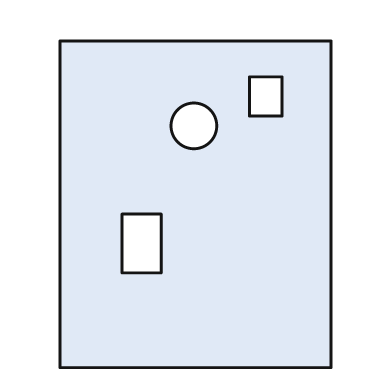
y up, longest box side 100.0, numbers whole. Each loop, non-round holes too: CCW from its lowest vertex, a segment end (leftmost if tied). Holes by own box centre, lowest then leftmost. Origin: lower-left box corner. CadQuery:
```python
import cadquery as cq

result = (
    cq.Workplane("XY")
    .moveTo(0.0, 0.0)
    .lineTo(83.0, 0.0)
    .lineTo(83.0, 100.0)
    .lineTo(0.0, 100.0)
    .close()
    .moveTo(19.0, 29.0)
    .lineTo(31.0, 29.0)
    .lineTo(31.0, 47.0)
    .lineTo(19.0, 47.0)
    .close()
    .moveTo(41.0, 74.0)
    .circle(7.0)
    .moveTo(58.0, 77.0)
    .lineTo(68.0, 77.0)
    .lineTo(68.0, 89.0)
    .lineTo(58.0, 89.0)
    .close()
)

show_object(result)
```